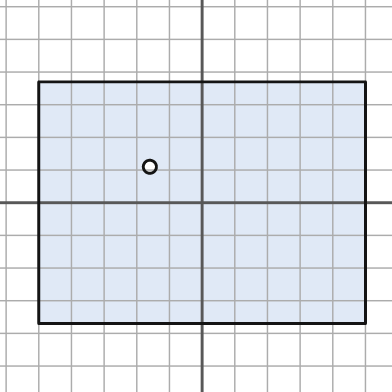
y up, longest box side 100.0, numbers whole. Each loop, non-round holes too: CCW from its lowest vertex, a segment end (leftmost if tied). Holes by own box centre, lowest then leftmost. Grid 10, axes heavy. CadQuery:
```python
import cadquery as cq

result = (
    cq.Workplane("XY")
    .moveTo(-50.0, -37.0)
    .lineTo(50.0, -37.0)
    .lineTo(50.0, 37.0)
    .lineTo(-50.0, 37.0)
    .close()
    .moveTo(-16.0, 11.0)
    .circle(2.0)
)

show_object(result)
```